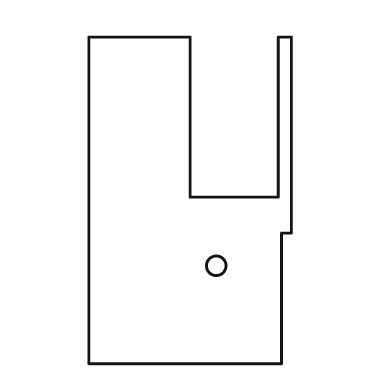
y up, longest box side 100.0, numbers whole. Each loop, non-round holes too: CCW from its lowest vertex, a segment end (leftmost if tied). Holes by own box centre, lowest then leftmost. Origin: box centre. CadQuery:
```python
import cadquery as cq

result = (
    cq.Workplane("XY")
    .moveTo(-31.0, -50.0)
    .lineTo(28.0, -50.0)
    .lineTo(28.0, -10.0)
    .lineTo(31.0, -10.0)
    .lineTo(31.0, 50.0)
    .lineTo(27.0, 50.0)
    .lineTo(27.0, 1.0)
    .lineTo(0.0, 1.0)
    .lineTo(0.0, 50.0)
    .lineTo(-31.0, 50.0)
    .close()
    .moveTo(8.0, -20.0)
    .circle(3.0)
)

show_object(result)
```